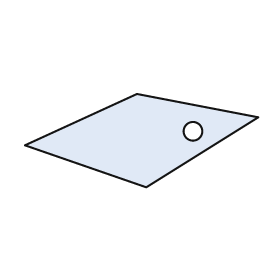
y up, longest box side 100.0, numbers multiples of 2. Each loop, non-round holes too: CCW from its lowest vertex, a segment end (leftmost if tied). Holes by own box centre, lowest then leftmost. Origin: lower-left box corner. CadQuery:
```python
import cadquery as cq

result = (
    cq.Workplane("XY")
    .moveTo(52.0, 0.0)
    .lineTo(100.0, 30.0)
    .lineTo(48.0, 40.0)
    .lineTo(0.0, 18.0)
    .close()
    .moveTo(72.0, 24.0)
    .circle(4.0)
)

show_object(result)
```